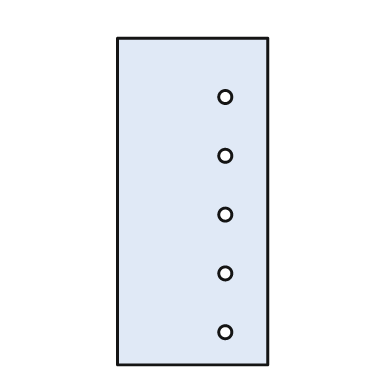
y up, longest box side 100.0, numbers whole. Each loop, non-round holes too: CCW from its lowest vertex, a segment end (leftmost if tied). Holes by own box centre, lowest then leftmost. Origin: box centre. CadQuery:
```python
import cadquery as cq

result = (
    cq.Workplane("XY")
    .moveTo(-23.0, -50.0)
    .lineTo(23.0, -50.0)
    .lineTo(23.0, 50.0)
    .lineTo(-23.0, 50.0)
    .close()
    .moveTo(10.0, -40.0)
    .circle(2.0)
    .moveTo(10.0, -22.0)
    .circle(2.0)
    .moveTo(10.0, -4.0)
    .circle(2.0)
    .moveTo(10.0, 14.0)
    .circle(2.0)
    .moveTo(10.0, 32.0)
    .circle(2.0)
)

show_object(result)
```